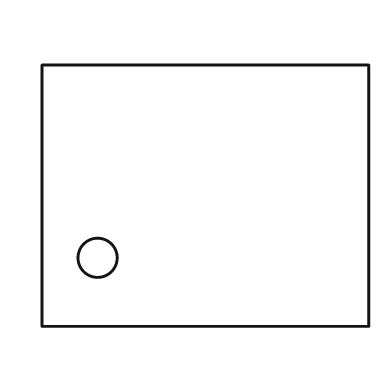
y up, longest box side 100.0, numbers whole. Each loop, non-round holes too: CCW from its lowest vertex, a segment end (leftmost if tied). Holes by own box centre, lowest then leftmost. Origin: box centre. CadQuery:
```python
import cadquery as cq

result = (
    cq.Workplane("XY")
    .moveTo(-50.0, -40.0)
    .lineTo(50.0, -40.0)
    .lineTo(50.0, 40.0)
    .lineTo(-50.0, 40.0)
    .close()
    .moveTo(-33.0, -19.0)
    .circle(6.0)
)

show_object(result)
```